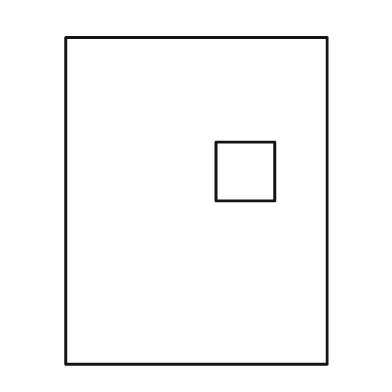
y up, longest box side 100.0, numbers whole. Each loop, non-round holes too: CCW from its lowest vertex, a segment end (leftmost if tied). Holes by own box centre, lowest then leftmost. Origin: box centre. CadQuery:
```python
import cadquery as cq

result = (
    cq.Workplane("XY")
    .moveTo(-40.0, -50.0)
    .lineTo(40.0, -50.0)
    .lineTo(40.0, 50.0)
    .lineTo(-40.0, 50.0)
    .close()
    .moveTo(6.0, 0.0)
    .lineTo(24.0, 0.0)
    .lineTo(24.0, 18.0)
    .lineTo(6.0, 18.0)
    .close()
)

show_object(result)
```